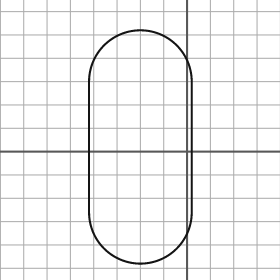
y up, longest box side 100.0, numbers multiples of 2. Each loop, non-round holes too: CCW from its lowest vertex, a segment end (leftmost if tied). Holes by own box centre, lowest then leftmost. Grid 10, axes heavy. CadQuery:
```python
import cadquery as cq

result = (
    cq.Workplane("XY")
    .moveTo(-42.0, -26.0)
    .threePointArc((-20.0, -48.0), (2.0, -26.0))
    .lineTo(2.0, 30.0)
    .threePointArc((-20.0, 52.0), (-42.0, 30.0))
    .close()
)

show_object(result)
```